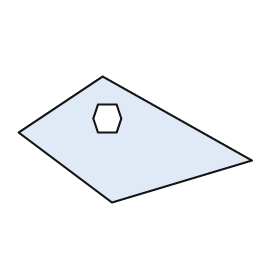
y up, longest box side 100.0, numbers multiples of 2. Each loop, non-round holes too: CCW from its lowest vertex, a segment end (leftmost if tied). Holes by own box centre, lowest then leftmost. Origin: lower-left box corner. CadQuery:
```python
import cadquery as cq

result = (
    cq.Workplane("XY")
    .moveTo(40.0, 0.0)
    .lineTo(100.0, 18.0)
    .lineTo(36.0, 54.0)
    .lineTo(0.0, 30.0)
    .close()
    .moveTo(34.0, 30.0)
    .lineTo(42.0, 30.0)
    .lineTo(44.0, 36.0)
    .lineTo(42.0, 42.0)
    .lineTo(34.0, 42.0)
    .lineTo(32.0, 36.0)
    .close()
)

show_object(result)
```